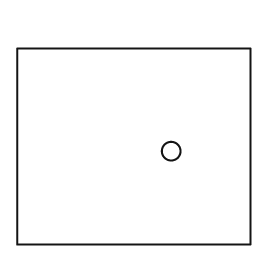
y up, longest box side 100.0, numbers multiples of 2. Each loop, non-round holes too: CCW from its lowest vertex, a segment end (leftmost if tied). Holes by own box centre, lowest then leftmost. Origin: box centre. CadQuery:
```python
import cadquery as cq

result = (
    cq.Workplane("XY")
    .moveTo(-50.0, -42.0)
    .lineTo(50.0, -42.0)
    .lineTo(50.0, 42.0)
    .lineTo(-50.0, 42.0)
    .close()
    .moveTo(16.0, -2.0)
    .circle(4.0)
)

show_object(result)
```